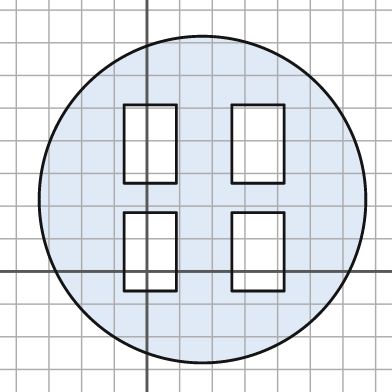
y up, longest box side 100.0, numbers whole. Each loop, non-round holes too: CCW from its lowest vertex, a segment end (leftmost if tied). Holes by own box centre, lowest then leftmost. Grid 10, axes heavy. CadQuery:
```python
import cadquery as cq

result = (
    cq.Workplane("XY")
    .moveTo(17.0, 22.0)
    .circle(50.0)
    .moveTo(-7.0, -6.0)
    .lineTo(9.0, -6.0)
    .lineTo(9.0, 18.0)
    .lineTo(-7.0, 18.0)
    .close()
    .moveTo(26.0, -6.0)
    .lineTo(42.0, -6.0)
    .lineTo(42.0, 18.0)
    .lineTo(26.0, 18.0)
    .close()
    .moveTo(-7.0, 27.0)
    .lineTo(9.0, 27.0)
    .lineTo(9.0, 51.0)
    .lineTo(-7.0, 51.0)
    .close()
    .moveTo(26.0, 27.0)
    .lineTo(42.0, 27.0)
    .lineTo(42.0, 51.0)
    .lineTo(26.0, 51.0)
    .close()
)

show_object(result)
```